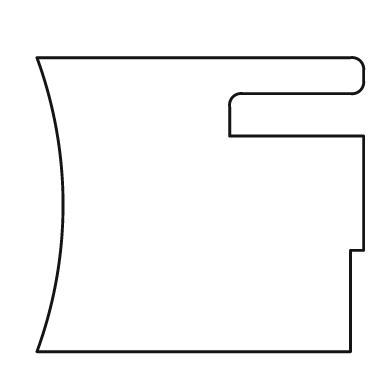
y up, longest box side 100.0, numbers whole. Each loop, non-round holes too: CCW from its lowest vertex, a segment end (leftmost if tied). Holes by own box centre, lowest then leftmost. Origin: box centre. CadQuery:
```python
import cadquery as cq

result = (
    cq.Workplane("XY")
    .moveTo(-50.0, -45.0)
    .lineTo(46.0, -45.0)
    .lineTo(46.0, -14.0)
    .lineTo(50.0, -14.0)
    .lineTo(50.0, 21.0)
    .lineTo(9.0, 21.0)
    .lineTo(9.0, 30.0)
    .threePointArc((10.0, 33.0), (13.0, 34.0))
    .lineTo(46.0, 34.0)
    .threePointArc((49.0, 35.0), (50.0, 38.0))
    .lineTo(50.0, 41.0)
    .threePointArc((49.0, 44.0), (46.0, 45.0))
    .lineTo(-50.0, 45.0)
    .threePointArc((-42.0, 0.0), (-50.0, -45.0))
    .close()
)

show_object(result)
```